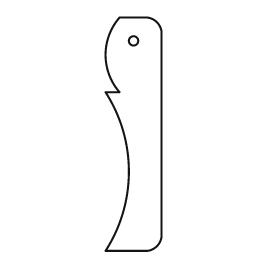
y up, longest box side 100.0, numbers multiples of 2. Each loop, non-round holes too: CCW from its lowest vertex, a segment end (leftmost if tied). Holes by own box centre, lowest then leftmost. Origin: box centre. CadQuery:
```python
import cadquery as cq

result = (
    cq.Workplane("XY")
    .moveTo(-12.0, -50.0)
    .lineTo(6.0, -50.0)
    .threePointArc((10.0, -48.0), (12.0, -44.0))
    .lineTo(12.0, 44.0)
    .threePointArc((10.0, 48.0), (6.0, 50.0))
    .lineTo(-6.0, 50.0)
    .threePointArc((-12.0, 34.0), (-6.0, 18.0))
    .lineTo(-12.0, 18.0)
    .threePointArc((-2.0, -16.0), (-12.0, -50.0))
    .close()
    .moveTo(0.0, 40.0)
    .circle(2.0)
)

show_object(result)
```